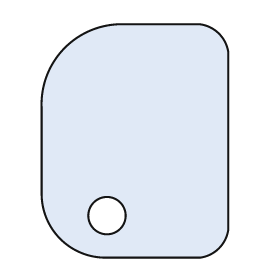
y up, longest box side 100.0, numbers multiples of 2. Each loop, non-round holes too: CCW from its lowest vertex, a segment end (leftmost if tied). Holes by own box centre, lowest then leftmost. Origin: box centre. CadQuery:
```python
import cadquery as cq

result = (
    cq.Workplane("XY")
    .moveTo(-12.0, -50.0)
    .lineTo(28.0, -50.0)
    .threePointArc((36.0, -46.0), (40.0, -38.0))
    .lineTo(40.0, 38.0)
    .threePointArc((36.0, 46.0), (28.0, 50.0))
    .lineTo(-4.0, 50.0)
    .threePointArc((-30.0, 40.0), (-40.0, 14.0))
    .lineTo(-40.0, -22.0)
    .threePointArc((-32.0, -42.0), (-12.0, -50.0))
    .close()
    .moveTo(-12.0, -32.0)
    .circle(8.0)
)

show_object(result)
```